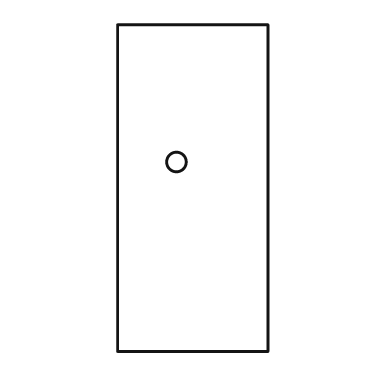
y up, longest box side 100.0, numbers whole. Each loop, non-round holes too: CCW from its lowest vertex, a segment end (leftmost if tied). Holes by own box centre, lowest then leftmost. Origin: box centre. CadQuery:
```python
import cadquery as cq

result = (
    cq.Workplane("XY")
    .moveTo(-23.0, -50.0)
    .lineTo(23.0, -50.0)
    .lineTo(23.0, 50.0)
    .lineTo(-23.0, 50.0)
    .close()
    .moveTo(-5.0, 8.0)
    .circle(3.0)
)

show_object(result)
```